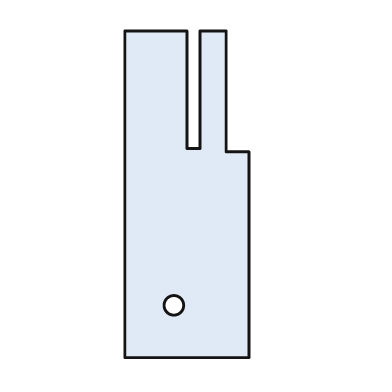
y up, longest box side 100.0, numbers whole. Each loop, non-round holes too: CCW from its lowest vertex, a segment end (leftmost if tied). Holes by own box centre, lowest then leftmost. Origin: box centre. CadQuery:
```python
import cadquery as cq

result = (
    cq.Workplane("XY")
    .moveTo(-19.0, -50.0)
    .lineTo(19.0, -50.0)
    .lineTo(19.0, 13.0)
    .lineTo(12.0, 13.0)
    .lineTo(12.0, 50.0)
    .lineTo(4.0, 50.0)
    .lineTo(4.0, 14.0)
    .lineTo(0.0, 14.0)
    .lineTo(0.0, 50.0)
    .lineTo(-19.0, 50.0)
    .close()
    .moveTo(-4.0, -34.0)
    .circle(3.0)
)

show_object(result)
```